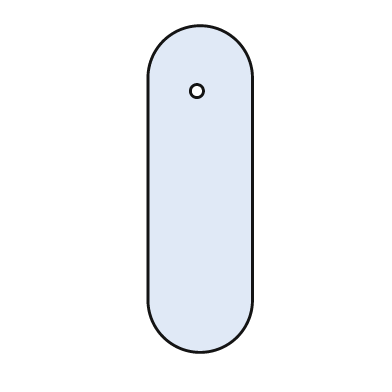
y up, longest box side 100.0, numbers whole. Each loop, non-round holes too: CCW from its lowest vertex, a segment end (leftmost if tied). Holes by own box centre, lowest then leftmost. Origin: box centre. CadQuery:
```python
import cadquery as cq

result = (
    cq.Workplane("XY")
    .moveTo(-16.0, -34.0)
    .threePointArc((0.0, -50.0), (16.0, -34.0))
    .lineTo(16.0, 34.0)
    .threePointArc((0.0, 50.0), (-16.0, 34.0))
    .close()
    .moveTo(-1.0, 30.0)
    .circle(2.0)
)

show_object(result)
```